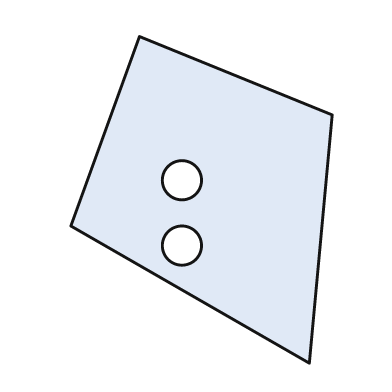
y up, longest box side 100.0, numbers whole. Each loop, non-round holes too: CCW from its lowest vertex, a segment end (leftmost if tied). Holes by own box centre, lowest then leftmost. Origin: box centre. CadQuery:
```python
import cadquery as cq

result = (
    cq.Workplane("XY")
    .moveTo(33.0, -50.0)
    .lineTo(40.0, 26.0)
    .lineTo(-19.0, 50.0)
    .lineTo(-40.0, -8.0)
    .close()
    .moveTo(-6.0, -14.0)
    .circle(6.0)
    .moveTo(-6.0, 6.0)
    .circle(6.0)
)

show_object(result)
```